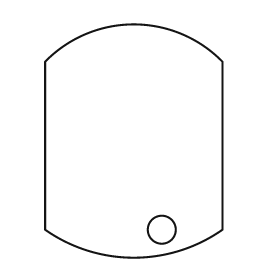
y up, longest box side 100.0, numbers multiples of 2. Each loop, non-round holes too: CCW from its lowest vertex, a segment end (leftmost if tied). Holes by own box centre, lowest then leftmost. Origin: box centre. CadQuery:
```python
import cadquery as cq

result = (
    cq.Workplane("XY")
    .moveTo(-38.0, -38.0)
    .threePointArc((0.0, -50.0), (38.0, -38.0))
    .lineTo(38.0, 34.0)
    .threePointArc((0.0, 50.0), (-38.0, 34.0))
    .close()
    .moveTo(12.0, -38.0)
    .circle(6.0)
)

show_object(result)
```